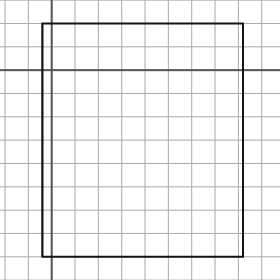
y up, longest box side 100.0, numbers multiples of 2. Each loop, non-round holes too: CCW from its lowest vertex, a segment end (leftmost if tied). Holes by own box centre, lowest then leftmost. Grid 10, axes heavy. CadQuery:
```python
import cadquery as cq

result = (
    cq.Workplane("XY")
    .moveTo(-4.0, -80.0)
    .lineTo(82.0, -80.0)
    .lineTo(82.0, 20.0)
    .lineTo(-4.0, 20.0)
    .close()
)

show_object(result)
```